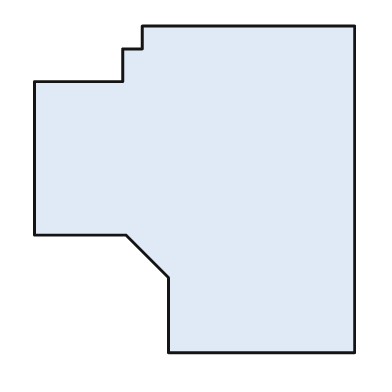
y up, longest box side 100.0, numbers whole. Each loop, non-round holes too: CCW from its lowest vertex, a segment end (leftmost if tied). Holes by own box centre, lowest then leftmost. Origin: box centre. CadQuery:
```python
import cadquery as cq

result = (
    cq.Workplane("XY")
    .moveTo(-8.0, -50.0)
    .lineTo(49.0, -50.0)
    .lineTo(49.0, 50.0)
    .lineTo(-16.0, 50.0)
    .lineTo(-16.0, 43.0)
    .lineTo(-22.0, 43.0)
    .lineTo(-22.0, 33.0)
    .lineTo(-49.0, 33.0)
    .lineTo(-49.0, -14.0)
    .lineTo(-21.0, -14.0)
    .lineTo(-8.0, -27.0)
    .close()
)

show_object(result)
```